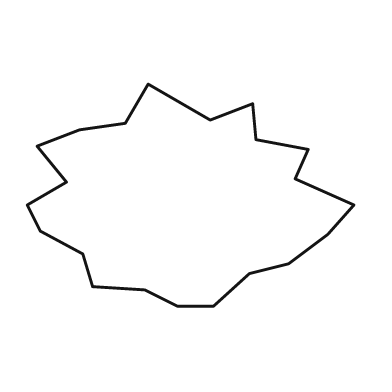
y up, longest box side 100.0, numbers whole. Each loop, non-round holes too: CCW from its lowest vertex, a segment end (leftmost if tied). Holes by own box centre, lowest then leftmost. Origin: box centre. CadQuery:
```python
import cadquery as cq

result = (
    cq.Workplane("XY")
    .moveTo(-4.0, -34.0)
    .lineTo(7.0, -34.0)
    .lineTo(18.0, -24.0)
    .lineTo(30.0, -21.0)
    .lineTo(42.0, -12.0)
    .lineTo(50.0, -3.0)
    .lineTo(32.0, 5.0)
    .lineTo(36.0, 14.0)
    .lineTo(20.0, 17.0)
    .lineTo(19.0, 28.0)
    .lineTo(6.0, 23.0)
    .lineTo(-13.0, 34.0)
    .lineTo(-20.0, 22.0)
    .lineTo(-34.0, 20.0)
    .lineTo(-47.0, 15.0)
    .lineTo(-38.0, 4.0)
    .lineTo(-50.0, -3.0)
    .lineTo(-46.0, -11.0)
    .lineTo(-33.0, -18.0)
    .lineTo(-30.0, -28.0)
    .lineTo(-14.0, -29.0)
    .close()
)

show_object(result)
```